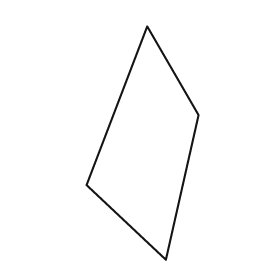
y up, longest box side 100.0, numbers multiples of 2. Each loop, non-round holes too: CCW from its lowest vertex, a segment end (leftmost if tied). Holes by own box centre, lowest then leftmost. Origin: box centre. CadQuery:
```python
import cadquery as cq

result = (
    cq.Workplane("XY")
    .moveTo(10.0, -50.0)
    .lineTo(24.0, 12.0)
    .lineTo(2.0, 50.0)
    .lineTo(-24.0, -18.0)
    .close()
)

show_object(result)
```